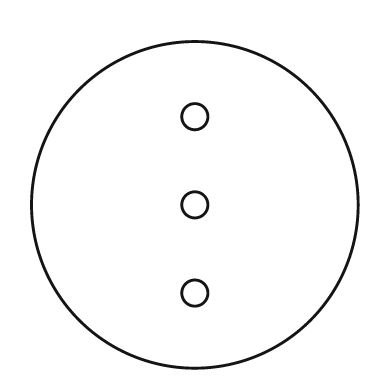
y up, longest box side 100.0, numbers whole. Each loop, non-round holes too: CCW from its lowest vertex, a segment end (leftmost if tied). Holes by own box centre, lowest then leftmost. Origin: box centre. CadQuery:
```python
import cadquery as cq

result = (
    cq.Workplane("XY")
    .moveTo(0.0, 0.0)
    .circle(50.0)
    .moveTo(0.0, -27.0)
    .circle(4.0)
    .moveTo(0.0, 0.0)
    .circle(4.0)
    .moveTo(0.0, 27.0)
    .circle(4.0)
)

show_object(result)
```